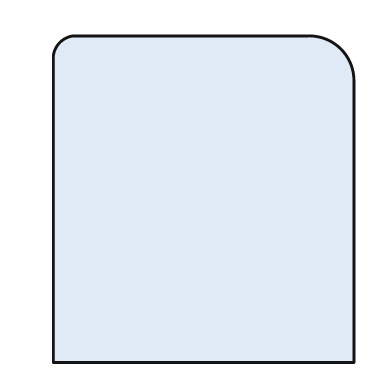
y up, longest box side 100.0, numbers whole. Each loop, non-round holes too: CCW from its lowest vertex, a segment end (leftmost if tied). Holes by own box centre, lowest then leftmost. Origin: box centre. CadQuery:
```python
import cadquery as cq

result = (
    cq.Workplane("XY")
    .moveTo(-46.0, -50.0)
    .lineTo(46.0, -50.0)
    .lineTo(46.0, 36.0)
    .threePointArc((42.0, 46.0), (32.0, 50.0))
    .lineTo(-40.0, 50.0)
    .threePointArc((-44.0, 48.0), (-46.0, 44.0))
    .close()
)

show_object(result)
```